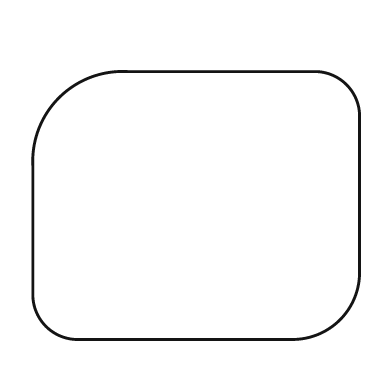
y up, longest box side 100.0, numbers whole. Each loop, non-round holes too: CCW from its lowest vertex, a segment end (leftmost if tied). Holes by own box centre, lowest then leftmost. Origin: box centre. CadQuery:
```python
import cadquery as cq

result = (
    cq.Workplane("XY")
    .moveTo(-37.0, -41.0)
    .lineTo(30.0, -41.0)
    .threePointArc((44.0, -35.0), (50.0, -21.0))
    .lineTo(50.0, 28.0)
    .threePointArc((46.0, 37.0), (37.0, 41.0))
    .lineTo(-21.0, 41.0)
    .threePointArc((-42.0, 33.0), (-50.0, 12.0))
    .lineTo(-50.0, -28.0)
    .threePointArc((-46.0, -37.0), (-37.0, -41.0))
    .close()
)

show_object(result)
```